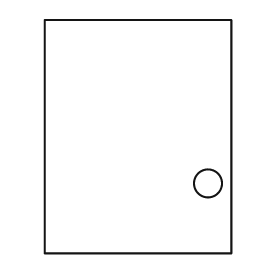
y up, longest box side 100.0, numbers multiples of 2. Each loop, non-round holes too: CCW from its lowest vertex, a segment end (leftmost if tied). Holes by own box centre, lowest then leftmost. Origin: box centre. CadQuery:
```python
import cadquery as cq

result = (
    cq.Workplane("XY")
    .moveTo(-40.0, -50.0)
    .lineTo(40.0, -50.0)
    .lineTo(40.0, 50.0)
    .lineTo(-40.0, 50.0)
    .close()
    .moveTo(30.0, -20.0)
    .circle(6.0)
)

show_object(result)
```